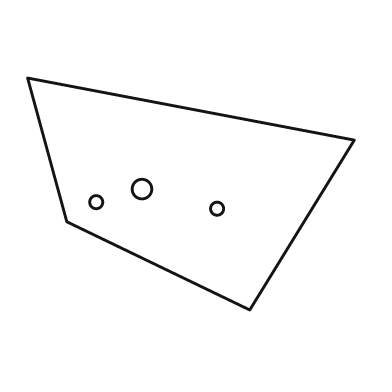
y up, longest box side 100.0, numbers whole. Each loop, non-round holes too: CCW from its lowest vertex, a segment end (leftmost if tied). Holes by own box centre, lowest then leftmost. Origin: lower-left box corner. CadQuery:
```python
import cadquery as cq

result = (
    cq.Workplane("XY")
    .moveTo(68.0, 0.0)
    .lineTo(100.0, 52.0)
    .lineTo(0.0, 71.0)
    .lineTo(12.0, 27.0)
    .close()
    .moveTo(58.0, 31.0)
    .circle(2.0)
    .moveTo(21.0, 33.0)
    .circle(2.0)
    .moveTo(35.0, 37.0)
    .circle(3.0)
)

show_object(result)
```